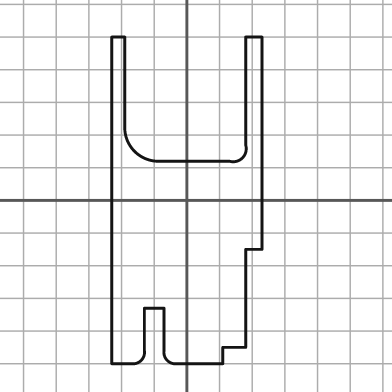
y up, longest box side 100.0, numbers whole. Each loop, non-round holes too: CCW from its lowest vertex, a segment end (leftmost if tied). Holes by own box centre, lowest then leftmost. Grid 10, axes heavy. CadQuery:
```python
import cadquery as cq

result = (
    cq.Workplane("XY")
    .moveTo(-23.0, -50.0)
    .lineTo(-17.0, -50.0)
    .threePointArc((-14.0, -49.0), (-13.0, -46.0))
    .lineTo(-13.0, -33.0)
    .lineTo(-7.0, -33.0)
    .lineTo(-7.0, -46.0)
    .threePointArc((-6.0, -49.0), (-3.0, -50.0))
    .lineTo(11.0, -50.0)
    .lineTo(11.0, -45.0)
    .lineTo(18.0, -45.0)
    .lineTo(18.0, -15.0)
    .lineTo(23.0, -15.0)
    .lineTo(23.0, 50.0)
    .lineTo(18.0, 50.0)
    .lineTo(18.0, 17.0)
    .threePointArc((17.0, 13.0), (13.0, 12.0))
    .lineTo(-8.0, 12.0)
    .threePointArc((-16.0, 15.0), (-19.0, 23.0))
    .lineTo(-19.0, 50.0)
    .lineTo(-23.0, 50.0)
    .close()
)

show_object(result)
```